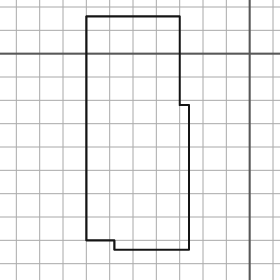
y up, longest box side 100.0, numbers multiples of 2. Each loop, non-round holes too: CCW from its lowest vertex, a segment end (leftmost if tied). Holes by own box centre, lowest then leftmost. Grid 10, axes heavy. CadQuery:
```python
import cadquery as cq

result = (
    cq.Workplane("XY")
    .moveTo(-58.0, -84.0)
    .lineTo(-26.0, -84.0)
    .lineTo(-26.0, -22.0)
    .lineTo(-30.0, -22.0)
    .lineTo(-30.0, 16.0)
    .lineTo(-70.0, 16.0)
    .lineTo(-70.0, -80.0)
    .lineTo(-58.0, -80.0)
    .close()
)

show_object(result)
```